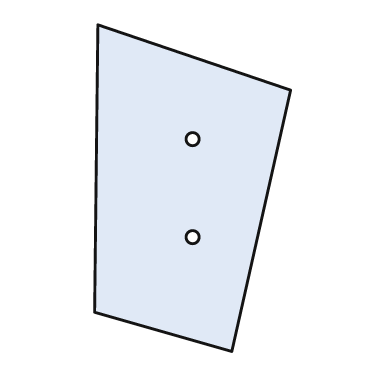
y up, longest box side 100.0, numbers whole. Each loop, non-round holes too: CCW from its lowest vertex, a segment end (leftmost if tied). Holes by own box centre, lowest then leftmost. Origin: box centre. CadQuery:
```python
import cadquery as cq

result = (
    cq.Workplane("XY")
    .moveTo(12.0, -50.0)
    .lineTo(30.0, 30.0)
    .lineTo(-29.0, 50.0)
    .lineTo(-30.0, -38.0)
    .close()
    .moveTo(0.0, -15.0)
    .circle(2.0)
    .moveTo(0.0, 15.0)
    .circle(2.0)
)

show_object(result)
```